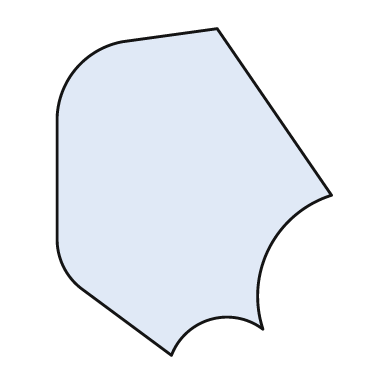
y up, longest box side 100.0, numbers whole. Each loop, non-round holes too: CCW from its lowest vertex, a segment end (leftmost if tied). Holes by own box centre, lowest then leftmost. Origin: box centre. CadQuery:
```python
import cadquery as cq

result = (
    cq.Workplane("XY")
    .moveTo(-7.0, -50.0)
    .threePointArc((5.0, -39.0), (21.0, -42.0))
    .threePointArc((23.0, -17.0), (42.0, -1.0))
    .lineTo(7.0, 50.0)
    .lineTo(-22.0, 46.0)
    .threePointArc((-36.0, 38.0), (-42.0, 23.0))
    .lineTo(-42.0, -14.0)
    .threePointArc((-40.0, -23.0), (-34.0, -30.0))
    .close()
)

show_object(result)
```